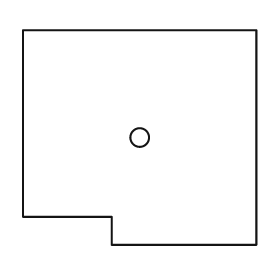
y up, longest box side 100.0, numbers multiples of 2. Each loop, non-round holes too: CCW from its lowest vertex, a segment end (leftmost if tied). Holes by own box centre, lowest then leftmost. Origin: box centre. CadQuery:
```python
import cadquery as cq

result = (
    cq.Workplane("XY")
    .moveTo(-12.0, -46.0)
    .lineTo(50.0, -46.0)
    .lineTo(50.0, 46.0)
    .lineTo(-50.0, 46.0)
    .lineTo(-50.0, -34.0)
    .lineTo(-12.0, -34.0)
    .close()
    .moveTo(0.0, 0.0)
    .circle(4.0)
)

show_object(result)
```